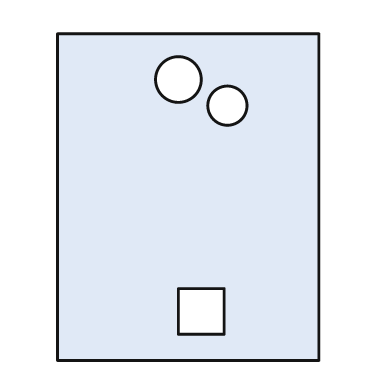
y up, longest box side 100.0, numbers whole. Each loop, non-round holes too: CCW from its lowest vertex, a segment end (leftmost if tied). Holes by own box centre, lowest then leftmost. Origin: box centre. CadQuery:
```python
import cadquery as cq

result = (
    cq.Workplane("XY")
    .moveTo(-40.0, -50.0)
    .lineTo(40.0, -50.0)
    .lineTo(40.0, 50.0)
    .lineTo(-40.0, 50.0)
    .close()
    .moveTo(-3.0, -42.0)
    .lineTo(11.0, -42.0)
    .lineTo(11.0, -28.0)
    .lineTo(-3.0, -28.0)
    .close()
    .moveTo(12.0, 28.0)
    .circle(6.0)
    .moveTo(-3.0, 36.0)
    .circle(7.0)
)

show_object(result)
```